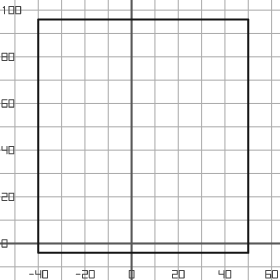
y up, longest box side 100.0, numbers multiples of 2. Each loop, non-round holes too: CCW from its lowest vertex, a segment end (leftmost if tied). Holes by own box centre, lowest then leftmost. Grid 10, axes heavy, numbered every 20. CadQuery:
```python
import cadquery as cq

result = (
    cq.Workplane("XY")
    .moveTo(-40.0, -4.0)
    .lineTo(50.0, -4.0)
    .lineTo(50.0, 96.0)
    .lineTo(-40.0, 96.0)
    .close()
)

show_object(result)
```